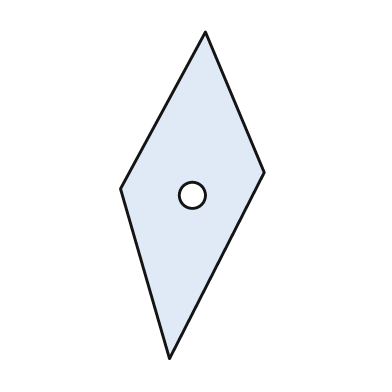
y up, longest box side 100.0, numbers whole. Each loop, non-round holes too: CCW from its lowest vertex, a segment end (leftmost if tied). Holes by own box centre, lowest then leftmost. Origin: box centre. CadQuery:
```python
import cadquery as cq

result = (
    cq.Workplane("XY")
    .moveTo(-7.0, -50.0)
    .lineTo(22.0, 7.0)
    .lineTo(4.0, 50.0)
    .lineTo(-22.0, 2.0)
    .close()
    .moveTo(0.0, 0.0)
    .circle(4.0)
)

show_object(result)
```